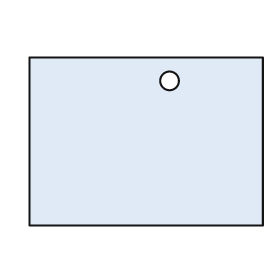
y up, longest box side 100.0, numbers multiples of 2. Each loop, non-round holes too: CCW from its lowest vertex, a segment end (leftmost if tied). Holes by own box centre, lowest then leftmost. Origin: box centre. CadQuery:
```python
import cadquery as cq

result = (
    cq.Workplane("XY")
    .moveTo(-50.0, -36.0)
    .lineTo(50.0, -36.0)
    .lineTo(50.0, 36.0)
    .lineTo(-50.0, 36.0)
    .close()
    .moveTo(10.0, 26.0)
    .circle(4.0)
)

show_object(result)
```